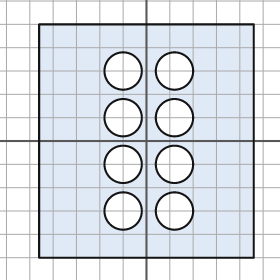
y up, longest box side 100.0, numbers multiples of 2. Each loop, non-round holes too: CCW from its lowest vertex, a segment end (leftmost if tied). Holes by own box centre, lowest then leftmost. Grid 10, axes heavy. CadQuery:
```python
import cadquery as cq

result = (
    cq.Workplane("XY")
    .moveTo(-46.0, -50.0)
    .lineTo(46.0, -50.0)
    .lineTo(46.0, 50.0)
    .lineTo(-46.0, 50.0)
    .close()
    .moveTo(-10.0, -30.0)
    .circle(8.0)
    .moveTo(12.0, -30.0)
    .circle(8.0)
    .moveTo(-10.0, -10.0)
    .circle(8.0)
    .moveTo(12.0, -10.0)
    .circle(8.0)
    .moveTo(-10.0, 10.0)
    .circle(8.0)
    .moveTo(12.0, 10.0)
    .circle(8.0)
    .moveTo(-10.0, 30.0)
    .circle(8.0)
    .moveTo(12.0, 30.0)
    .circle(8.0)
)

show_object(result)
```